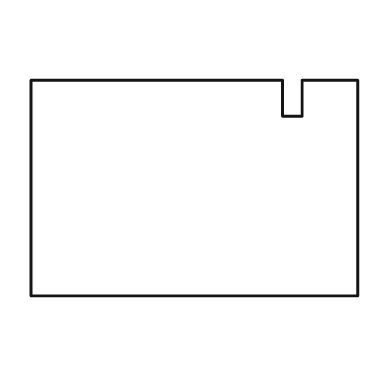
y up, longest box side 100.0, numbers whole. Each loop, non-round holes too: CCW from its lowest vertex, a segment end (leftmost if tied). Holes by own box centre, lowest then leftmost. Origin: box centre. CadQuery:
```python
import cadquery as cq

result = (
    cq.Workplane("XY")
    .moveTo(-50.0, -33.0)
    .lineTo(50.0, -33.0)
    .lineTo(50.0, 33.0)
    .lineTo(33.0, 33.0)
    .lineTo(33.0, 22.0)
    .lineTo(27.0, 22.0)
    .lineTo(27.0, 33.0)
    .lineTo(-50.0, 33.0)
    .close()
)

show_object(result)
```